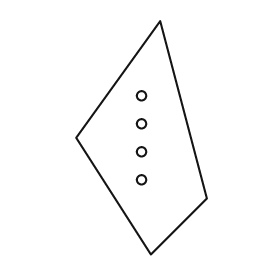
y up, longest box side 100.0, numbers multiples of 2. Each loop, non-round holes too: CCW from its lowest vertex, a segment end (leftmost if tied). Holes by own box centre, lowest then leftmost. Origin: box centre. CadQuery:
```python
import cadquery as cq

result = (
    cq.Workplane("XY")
    .moveTo(4.0, -50.0)
    .lineTo(28.0, -26.0)
    .lineTo(8.0, 50.0)
    .lineTo(-28.0, 0.0)
    .close()
    .moveTo(0.0, -18.0)
    .circle(2.0)
    .moveTo(0.0, -6.0)
    .circle(2.0)
    .moveTo(0.0, 6.0)
    .circle(2.0)
    .moveTo(0.0, 18.0)
    .circle(2.0)
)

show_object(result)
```